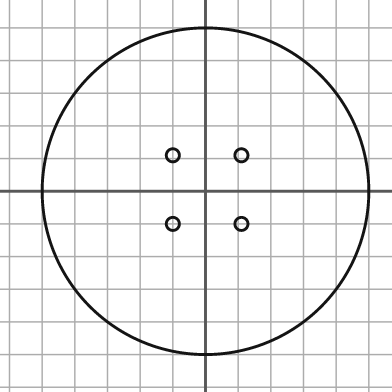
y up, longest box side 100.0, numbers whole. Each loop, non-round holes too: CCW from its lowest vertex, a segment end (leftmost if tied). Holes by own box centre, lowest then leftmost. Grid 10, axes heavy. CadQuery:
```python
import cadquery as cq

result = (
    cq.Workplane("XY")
    .moveTo(0.0, 0.0)
    .circle(50.0)
    .moveTo(-10.0, -10.0)
    .circle(2.0)
    .moveTo(11.0, -10.0)
    .circle(2.0)
    .moveTo(-10.0, 11.0)
    .circle(2.0)
    .moveTo(11.0, 11.0)
    .circle(2.0)
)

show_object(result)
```